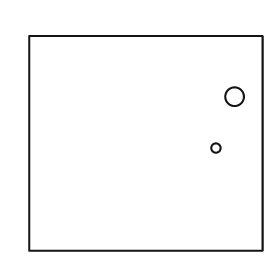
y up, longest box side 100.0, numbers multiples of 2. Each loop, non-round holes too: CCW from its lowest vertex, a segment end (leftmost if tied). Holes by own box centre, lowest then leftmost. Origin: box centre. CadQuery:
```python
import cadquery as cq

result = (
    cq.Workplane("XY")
    .moveTo(-50.0, -46.0)
    .lineTo(50.0, -46.0)
    .lineTo(50.0, 46.0)
    .lineTo(-50.0, 46.0)
    .close()
    .moveTo(30.0, -2.0)
    .circle(2.0)
    .moveTo(38.0, 20.0)
    .circle(4.0)
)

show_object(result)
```